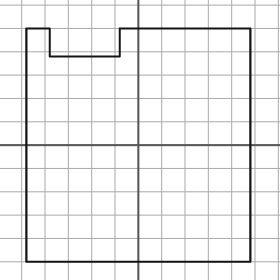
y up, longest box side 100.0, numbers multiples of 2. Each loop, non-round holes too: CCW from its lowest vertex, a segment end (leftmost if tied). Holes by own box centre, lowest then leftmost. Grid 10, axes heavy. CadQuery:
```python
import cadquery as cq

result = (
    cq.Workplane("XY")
    .moveTo(-48.0, -50.0)
    .lineTo(48.0, -50.0)
    .lineTo(48.0, 50.0)
    .lineTo(-8.0, 50.0)
    .lineTo(-8.0, 38.0)
    .lineTo(-38.0, 38.0)
    .lineTo(-38.0, 50.0)
    .lineTo(-48.0, 50.0)
    .close()
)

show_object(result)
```